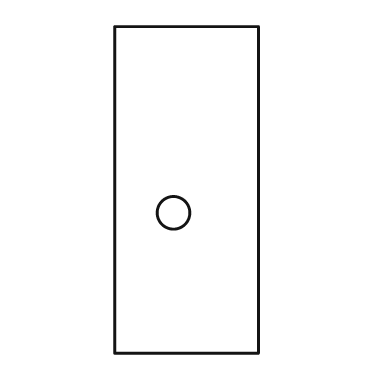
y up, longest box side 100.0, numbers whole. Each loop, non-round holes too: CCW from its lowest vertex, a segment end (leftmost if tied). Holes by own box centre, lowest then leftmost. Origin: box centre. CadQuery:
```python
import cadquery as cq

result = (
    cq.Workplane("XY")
    .moveTo(-22.0, -50.0)
    .lineTo(22.0, -50.0)
    .lineTo(22.0, 50.0)
    .lineTo(-22.0, 50.0)
    .close()
    .moveTo(-4.0, -7.0)
    .circle(5.0)
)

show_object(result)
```